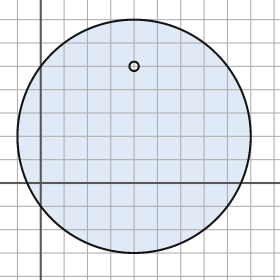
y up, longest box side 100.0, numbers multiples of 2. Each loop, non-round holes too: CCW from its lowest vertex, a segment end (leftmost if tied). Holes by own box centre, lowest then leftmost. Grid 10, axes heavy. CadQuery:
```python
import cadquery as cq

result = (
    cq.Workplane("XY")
    .moveTo(40.0, 20.0)
    .circle(50.0)
    .moveTo(40.0, 50.0)
    .circle(2.0)
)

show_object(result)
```